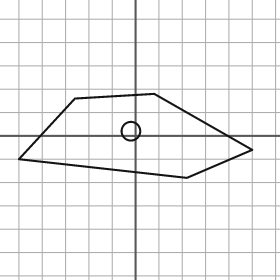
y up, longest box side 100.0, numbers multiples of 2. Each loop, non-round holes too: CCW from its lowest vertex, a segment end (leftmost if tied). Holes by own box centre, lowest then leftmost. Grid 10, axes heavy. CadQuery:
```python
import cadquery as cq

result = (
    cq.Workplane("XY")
    .moveTo(22.0, -18.0)
    .lineTo(50.0, -6.0)
    .lineTo(8.0, 18.0)
    .lineTo(-26.0, 16.0)
    .lineTo(-50.0, -10.0)
    .close()
    .moveTo(-2.0, 2.0)
    .circle(4.0)
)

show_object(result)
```